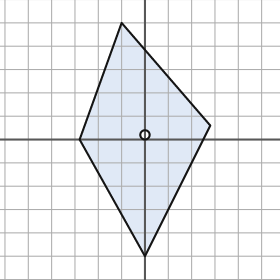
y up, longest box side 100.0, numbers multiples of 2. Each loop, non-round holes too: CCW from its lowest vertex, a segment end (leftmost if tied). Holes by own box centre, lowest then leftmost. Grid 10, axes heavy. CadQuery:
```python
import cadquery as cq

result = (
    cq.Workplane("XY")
    .moveTo(0.0, -50.0)
    .lineTo(28.0, 6.0)
    .lineTo(-10.0, 50.0)
    .lineTo(-28.0, 0.0)
    .close()
    .moveTo(0.0, 2.0)
    .circle(2.0)
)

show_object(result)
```